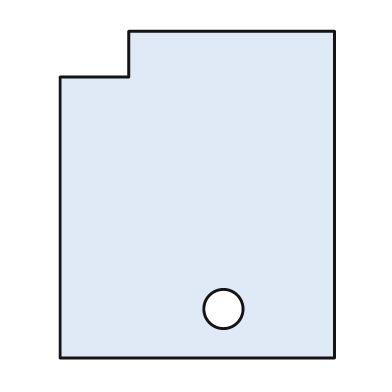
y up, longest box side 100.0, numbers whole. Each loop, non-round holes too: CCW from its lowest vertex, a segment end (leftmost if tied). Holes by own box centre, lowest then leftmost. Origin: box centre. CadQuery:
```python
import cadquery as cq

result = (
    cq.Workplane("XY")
    .moveTo(-42.0, -50.0)
    .lineTo(42.0, -50.0)
    .lineTo(42.0, 50.0)
    .lineTo(-21.0, 50.0)
    .lineTo(-21.0, 36.0)
    .lineTo(-42.0, 36.0)
    .close()
    .moveTo(8.0, -35.0)
    .circle(6.0)
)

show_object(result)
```